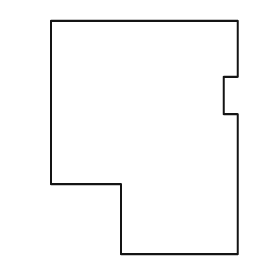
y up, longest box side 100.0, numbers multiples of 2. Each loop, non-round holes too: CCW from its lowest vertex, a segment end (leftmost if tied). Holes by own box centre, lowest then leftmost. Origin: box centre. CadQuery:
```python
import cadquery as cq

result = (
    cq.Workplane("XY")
    .moveTo(-10.0, -50.0)
    .lineTo(40.0, -50.0)
    .lineTo(40.0, 10.0)
    .lineTo(34.0, 10.0)
    .lineTo(34.0, 26.0)
    .lineTo(40.0, 26.0)
    .lineTo(40.0, 50.0)
    .lineTo(-40.0, 50.0)
    .lineTo(-40.0, -20.0)
    .lineTo(-10.0, -20.0)
    .close()
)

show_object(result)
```